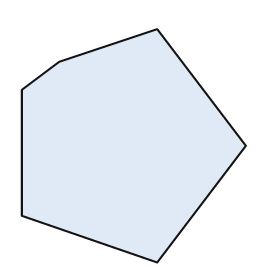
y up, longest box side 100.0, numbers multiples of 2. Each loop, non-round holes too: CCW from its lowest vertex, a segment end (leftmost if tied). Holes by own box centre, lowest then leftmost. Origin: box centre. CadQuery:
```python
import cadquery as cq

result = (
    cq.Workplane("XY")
    .moveTo(10.0, -50.0)
    .lineTo(48.0, 0.0)
    .lineTo(10.0, 50.0)
    .lineTo(-32.0, 36.0)
    .lineTo(-48.0, 24.0)
    .lineTo(-48.0, -30.0)
    .close()
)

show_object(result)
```